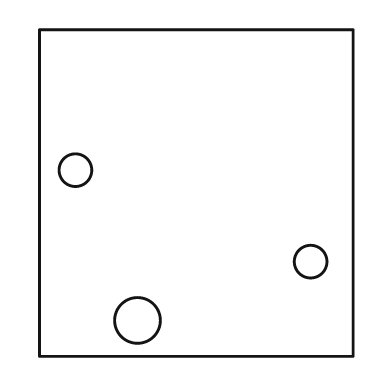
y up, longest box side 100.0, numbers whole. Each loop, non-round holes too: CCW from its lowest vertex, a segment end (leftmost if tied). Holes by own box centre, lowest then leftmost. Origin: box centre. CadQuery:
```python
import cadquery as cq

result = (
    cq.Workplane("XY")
    .moveTo(-48.0, -50.0)
    .lineTo(48.0, -50.0)
    .lineTo(48.0, 50.0)
    .lineTo(-48.0, 50.0)
    .close()
    .moveTo(-18.0, -39.0)
    .circle(7.0)
    .moveTo(35.0, -21.0)
    .circle(5.0)
    .moveTo(-37.0, 7.0)
    .circle(5.0)
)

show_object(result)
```